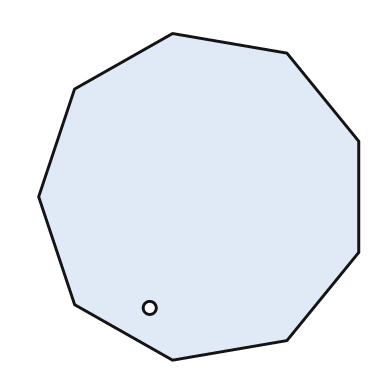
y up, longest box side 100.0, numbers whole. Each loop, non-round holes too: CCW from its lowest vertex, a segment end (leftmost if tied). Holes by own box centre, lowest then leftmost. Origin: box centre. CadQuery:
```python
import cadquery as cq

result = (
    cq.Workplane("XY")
    .moveTo(-8.0, -50.0)
    .lineTo(27.0, -44.0)
    .lineTo(49.0, -17.0)
    .lineTo(49.0, 17.0)
    .lineTo(27.0, 44.0)
    .lineTo(-8.0, 50.0)
    .lineTo(-38.0, 33.0)
    .lineTo(-49.0, 0.0)
    .lineTo(-38.0, -33.0)
    .close()
    .moveTo(-15.0, -34.0)
    .circle(2.0)
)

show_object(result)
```